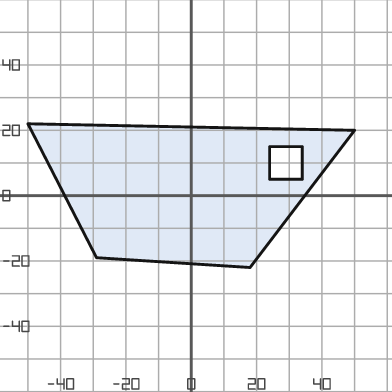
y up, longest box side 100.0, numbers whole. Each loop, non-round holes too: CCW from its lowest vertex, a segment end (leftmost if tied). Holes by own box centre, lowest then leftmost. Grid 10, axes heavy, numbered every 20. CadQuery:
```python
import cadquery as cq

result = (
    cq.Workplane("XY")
    .moveTo(18.0, -22.0)
    .lineTo(50.0, 20.0)
    .lineTo(-50.0, 22.0)
    .lineTo(-29.0, -19.0)
    .close()
    .moveTo(24.0, 5.0)
    .lineTo(34.0, 5.0)
    .lineTo(34.0, 15.0)
    .lineTo(24.0, 15.0)
    .close()
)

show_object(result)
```